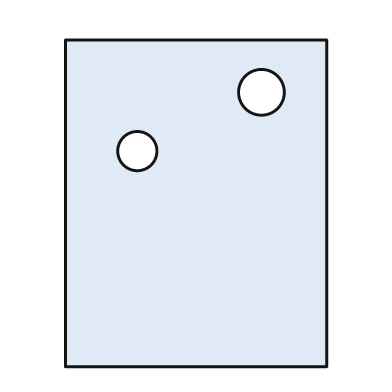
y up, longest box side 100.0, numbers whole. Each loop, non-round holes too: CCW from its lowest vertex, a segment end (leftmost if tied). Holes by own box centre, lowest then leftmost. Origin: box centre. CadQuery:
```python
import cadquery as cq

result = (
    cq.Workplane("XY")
    .moveTo(-40.0, -50.0)
    .lineTo(40.0, -50.0)
    .lineTo(40.0, 50.0)
    .lineTo(-40.0, 50.0)
    .close()
    .moveTo(-18.0, 16.0)
    .circle(6.0)
    .moveTo(20.0, 34.0)
    .circle(7.0)
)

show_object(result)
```